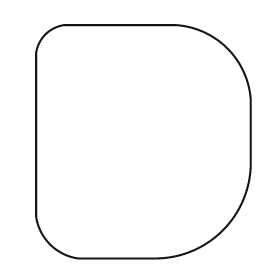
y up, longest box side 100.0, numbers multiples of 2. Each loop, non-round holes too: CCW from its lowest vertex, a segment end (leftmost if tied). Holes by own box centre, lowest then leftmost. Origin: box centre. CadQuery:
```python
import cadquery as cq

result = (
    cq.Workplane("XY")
    .moveTo(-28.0, -50.0)
    .lineTo(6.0, -50.0)
    .threePointArc((34.0, -38.0), (46.0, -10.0))
    .lineTo(46.0, 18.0)
    .threePointArc((36.0, 40.0), (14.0, 50.0))
    .lineTo(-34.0, 50.0)
    .threePointArc((-42.0, 46.0), (-46.0, 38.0))
    .lineTo(-46.0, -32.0)
    .threePointArc((-40.0, -44.0), (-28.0, -50.0))
    .close()
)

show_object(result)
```